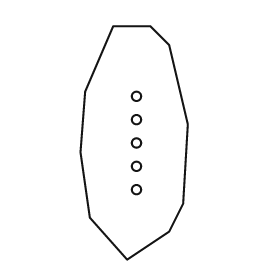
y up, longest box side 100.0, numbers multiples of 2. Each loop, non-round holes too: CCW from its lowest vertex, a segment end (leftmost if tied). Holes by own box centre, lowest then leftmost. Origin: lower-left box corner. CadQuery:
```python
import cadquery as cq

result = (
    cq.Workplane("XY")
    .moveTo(20.0, 0.0)
    .lineTo(38.0, 12.0)
    .lineTo(44.0, 24.0)
    .lineTo(46.0, 58.0)
    .lineTo(38.0, 92.0)
    .lineTo(30.0, 100.0)
    .lineTo(14.0, 100.0)
    .lineTo(2.0, 72.0)
    .lineTo(0.0, 46.0)
    .lineTo(4.0, 18.0)
    .close()
    .moveTo(24.0, 30.0)
    .circle(2.0)
    .moveTo(24.0, 40.0)
    .circle(2.0)
    .moveTo(24.0, 50.0)
    .circle(2.0)
    .moveTo(24.0, 60.0)
    .circle(2.0)
    .moveTo(24.0, 70.0)
    .circle(2.0)
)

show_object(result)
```